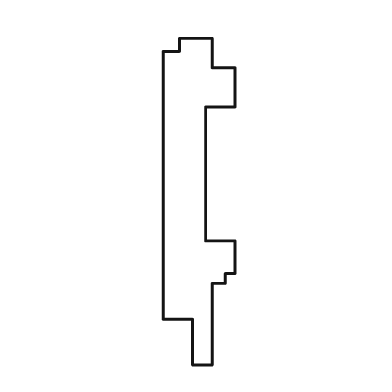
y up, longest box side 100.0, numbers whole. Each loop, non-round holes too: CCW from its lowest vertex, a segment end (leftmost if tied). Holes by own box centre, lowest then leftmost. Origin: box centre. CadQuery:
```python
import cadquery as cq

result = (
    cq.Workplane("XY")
    .moveTo(-2.0, -50.0)
    .lineTo(4.0, -50.0)
    .lineTo(4.0, -25.0)
    .lineTo(8.0, -25.0)
    .lineTo(8.0, -22.0)
    .lineTo(11.0, -22.0)
    .lineTo(11.0, -12.0)
    .lineTo(2.0, -12.0)
    .lineTo(2.0, 29.0)
    .lineTo(11.0, 29.0)
    .lineTo(11.0, 41.0)
    .lineTo(4.0, 41.0)
    .lineTo(4.0, 50.0)
    .lineTo(-6.0, 50.0)
    .lineTo(-6.0, 46.0)
    .lineTo(-11.0, 46.0)
    .lineTo(-11.0, -36.0)
    .lineTo(-2.0, -36.0)
    .close()
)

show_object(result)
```